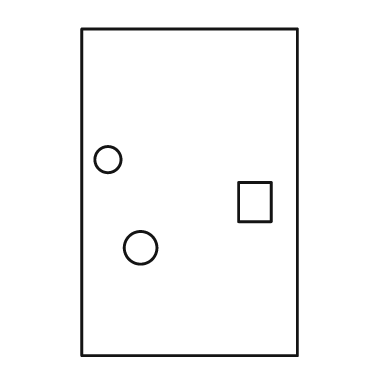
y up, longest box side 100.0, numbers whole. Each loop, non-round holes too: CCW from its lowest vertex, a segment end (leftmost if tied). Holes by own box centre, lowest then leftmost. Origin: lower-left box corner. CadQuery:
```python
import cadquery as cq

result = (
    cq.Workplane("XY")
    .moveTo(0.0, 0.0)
    .lineTo(66.0, 0.0)
    .lineTo(66.0, 100.0)
    .lineTo(0.0, 100.0)
    .close()
    .moveTo(18.0, 33.0)
    .circle(5.0)
    .moveTo(48.0, 41.0)
    .lineTo(58.0, 41.0)
    .lineTo(58.0, 53.0)
    .lineTo(48.0, 53.0)
    .close()
    .moveTo(8.0, 60.0)
    .circle(4.0)
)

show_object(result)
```